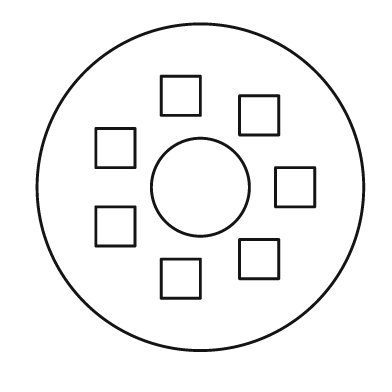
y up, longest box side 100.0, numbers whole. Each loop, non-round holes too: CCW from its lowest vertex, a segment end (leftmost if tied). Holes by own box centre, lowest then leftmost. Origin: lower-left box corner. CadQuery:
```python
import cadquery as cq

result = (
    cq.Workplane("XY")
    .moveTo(50.0, 50.0)
    .circle(50.0)
    .moveTo(38.0, 16.0)
    .lineTo(50.0, 16.0)
    .lineTo(50.0, 28.0)
    .lineTo(38.0, 28.0)
    .close()
    .moveTo(62.0, 22.0)
    .lineTo(74.0, 22.0)
    .lineTo(74.0, 34.0)
    .lineTo(62.0, 34.0)
    .close()
    .moveTo(18.0, 32.0)
    .lineTo(30.0, 32.0)
    .lineTo(30.0, 44.0)
    .lineTo(18.0, 44.0)
    .close()
    .moveTo(50.0, 50.0)
    .circle(15.0)
    .moveTo(73.0, 44.0)
    .lineTo(85.0, 44.0)
    .lineTo(85.0, 56.0)
    .lineTo(73.0, 56.0)
    .close()
    .moveTo(18.0, 56.0)
    .lineTo(30.0, 56.0)
    .lineTo(30.0, 68.0)
    .lineTo(18.0, 68.0)
    .close()
    .moveTo(62.0, 66.0)
    .lineTo(74.0, 66.0)
    .lineTo(74.0, 78.0)
    .lineTo(62.0, 78.0)
    .close()
    .moveTo(38.0, 72.0)
    .lineTo(50.0, 72.0)
    .lineTo(50.0, 84.0)
    .lineTo(38.0, 84.0)
    .close()
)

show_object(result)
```